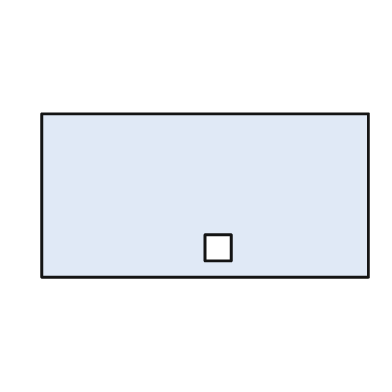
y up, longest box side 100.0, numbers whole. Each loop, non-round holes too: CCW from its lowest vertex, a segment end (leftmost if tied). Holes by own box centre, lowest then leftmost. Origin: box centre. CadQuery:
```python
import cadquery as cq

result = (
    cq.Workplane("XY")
    .moveTo(-50.0, -25.0)
    .lineTo(50.0, -25.0)
    .lineTo(50.0, 25.0)
    .lineTo(-50.0, 25.0)
    .close()
    .moveTo(0.0, -20.0)
    .lineTo(8.0, -20.0)
    .lineTo(8.0, -12.0)
    .lineTo(0.0, -12.0)
    .close()
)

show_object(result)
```